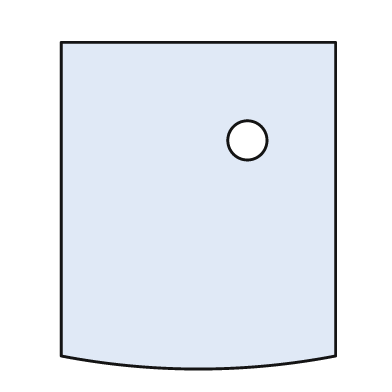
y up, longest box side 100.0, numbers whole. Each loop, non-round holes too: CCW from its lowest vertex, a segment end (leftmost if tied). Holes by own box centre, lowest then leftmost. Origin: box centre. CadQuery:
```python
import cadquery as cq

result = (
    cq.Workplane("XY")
    .moveTo(-42.0, -46.0)
    .threePointArc((0.0, -50.0), (42.0, -46.0))
    .lineTo(42.0, 50.0)
    .lineTo(-42.0, 50.0)
    .close()
    .moveTo(15.0, 20.0)
    .circle(6.0)
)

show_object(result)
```